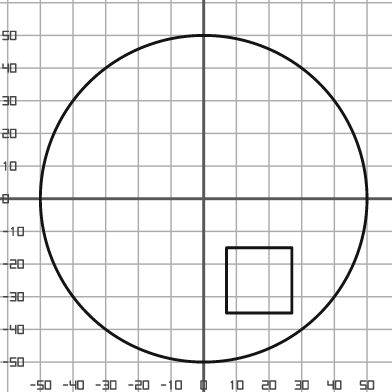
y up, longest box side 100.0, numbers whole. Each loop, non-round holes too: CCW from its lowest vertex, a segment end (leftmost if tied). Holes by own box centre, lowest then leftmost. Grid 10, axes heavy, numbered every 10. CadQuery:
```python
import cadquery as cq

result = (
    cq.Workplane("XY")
    .moveTo(0.0, 0.0)
    .circle(50.0)
    .moveTo(7.0, -35.0)
    .lineTo(27.0, -35.0)
    .lineTo(27.0, -15.0)
    .lineTo(7.0, -15.0)
    .close()
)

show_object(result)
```